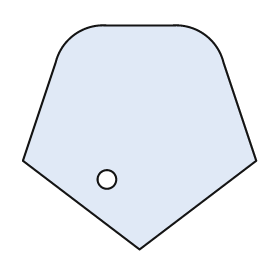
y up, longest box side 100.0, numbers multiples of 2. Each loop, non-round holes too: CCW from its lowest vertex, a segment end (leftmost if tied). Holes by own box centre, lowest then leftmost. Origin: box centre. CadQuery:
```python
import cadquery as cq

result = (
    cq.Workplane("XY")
    .moveTo(0.0, -48.0)
    .lineTo(50.0, -10.0)
    .lineTo(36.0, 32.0)
    .threePointArc((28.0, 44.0), (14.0, 48.0))
    .lineTo(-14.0, 48.0)
    .threePointArc((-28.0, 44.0), (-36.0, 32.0))
    .lineTo(-50.0, -10.0)
    .close()
    .moveTo(-14.0, -18.0)
    .circle(4.0)
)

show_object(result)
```